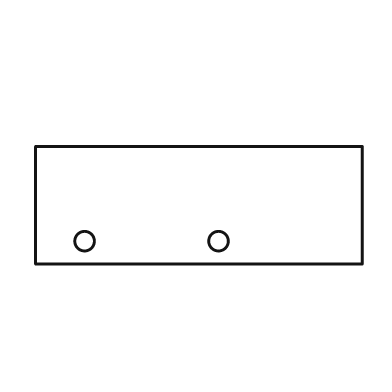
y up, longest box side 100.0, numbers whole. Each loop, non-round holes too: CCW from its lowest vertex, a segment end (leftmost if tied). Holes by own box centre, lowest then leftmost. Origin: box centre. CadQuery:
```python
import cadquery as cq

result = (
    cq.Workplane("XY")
    .moveTo(-50.0, -18.0)
    .lineTo(50.0, -18.0)
    .lineTo(50.0, 18.0)
    .lineTo(-50.0, 18.0)
    .close()
    .moveTo(-35.0, -11.0)
    .circle(3.0)
    .moveTo(6.0, -11.0)
    .circle(3.0)
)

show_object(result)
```